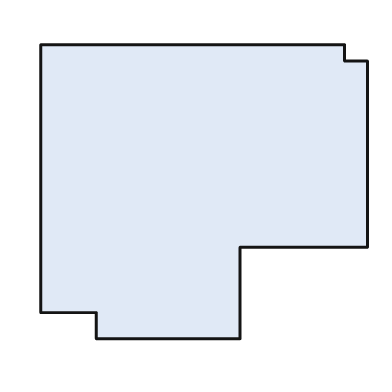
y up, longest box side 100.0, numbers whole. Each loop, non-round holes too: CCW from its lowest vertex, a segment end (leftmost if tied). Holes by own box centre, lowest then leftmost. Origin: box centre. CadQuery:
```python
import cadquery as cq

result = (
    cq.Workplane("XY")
    .moveTo(-33.0, -45.0)
    .lineTo(11.0, -45.0)
    .lineTo(11.0, -17.0)
    .lineTo(50.0, -17.0)
    .lineTo(50.0, 40.0)
    .lineTo(43.0, 40.0)
    .lineTo(43.0, 45.0)
    .lineTo(-50.0, 45.0)
    .lineTo(-50.0, -37.0)
    .lineTo(-33.0, -37.0)
    .close()
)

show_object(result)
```